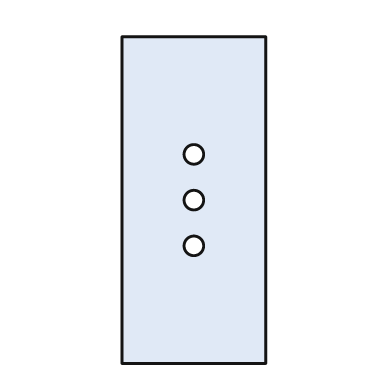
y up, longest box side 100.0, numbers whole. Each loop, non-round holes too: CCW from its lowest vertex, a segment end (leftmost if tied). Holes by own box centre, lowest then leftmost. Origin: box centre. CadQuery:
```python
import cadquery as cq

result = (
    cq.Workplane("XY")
    .moveTo(-22.0, -50.0)
    .lineTo(22.0, -50.0)
    .lineTo(22.0, 50.0)
    .lineTo(-22.0, 50.0)
    .close()
    .moveTo(0.0, -14.0)
    .circle(3.0)
    .moveTo(0.0, 0.0)
    .circle(3.0)
    .moveTo(0.0, 14.0)
    .circle(3.0)
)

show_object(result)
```